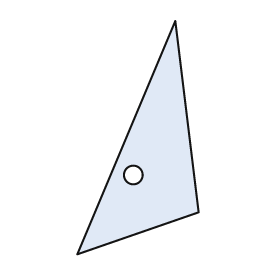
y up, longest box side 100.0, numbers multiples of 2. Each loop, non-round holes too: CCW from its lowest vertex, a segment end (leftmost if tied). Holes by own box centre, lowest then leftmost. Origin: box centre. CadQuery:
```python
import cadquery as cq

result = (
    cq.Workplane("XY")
    .moveTo(-26.0, -50.0)
    .lineTo(26.0, -32.0)
    .lineTo(16.0, 50.0)
    .close()
    .moveTo(-2.0, -16.0)
    .circle(4.0)
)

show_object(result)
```